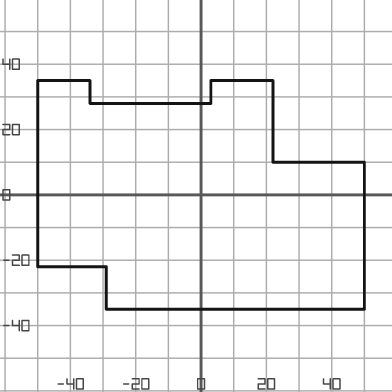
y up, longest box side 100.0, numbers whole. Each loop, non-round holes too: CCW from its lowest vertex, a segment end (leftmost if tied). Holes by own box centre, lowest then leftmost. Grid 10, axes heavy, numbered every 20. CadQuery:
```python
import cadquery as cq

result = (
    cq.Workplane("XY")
    .moveTo(-29.0, -35.0)
    .lineTo(50.0, -35.0)
    .lineTo(50.0, 10.0)
    .lineTo(22.0, 10.0)
    .lineTo(22.0, 35.0)
    .lineTo(3.0, 35.0)
    .lineTo(3.0, 28.0)
    .lineTo(-34.0, 28.0)
    .lineTo(-34.0, 35.0)
    .lineTo(-50.0, 35.0)
    .lineTo(-50.0, -22.0)
    .lineTo(-29.0, -22.0)
    .close()
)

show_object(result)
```